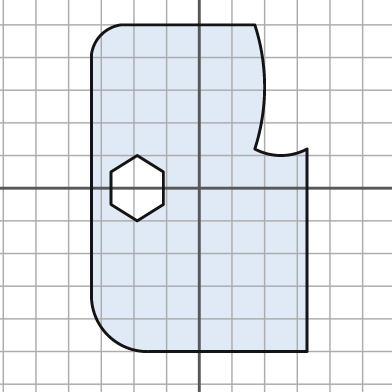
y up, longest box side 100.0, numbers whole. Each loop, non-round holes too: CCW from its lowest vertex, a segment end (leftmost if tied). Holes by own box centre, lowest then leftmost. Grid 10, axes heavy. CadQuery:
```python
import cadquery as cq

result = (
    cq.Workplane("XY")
    .moveTo(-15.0, -50.0)
    .lineTo(33.0, -50.0)
    .lineTo(33.0, 12.0)
    .threePointArc((25.0, 10.0), (17.0, 12.0))
    .threePointArc((20.0, 31.0), (17.0, 50.0))
    .lineTo(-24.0, 50.0)
    .threePointArc((-30.0, 47.0), (-33.0, 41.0))
    .lineTo(-33.0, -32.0)
    .threePointArc((-28.0, -45.0), (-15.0, -50.0))
    .close()
    .moveTo(-19.0, -10.0)
    .lineTo(-11.0, -5.0)
    .lineTo(-11.0, 5.0)
    .lineTo(-19.0, 10.0)
    .lineTo(-27.0, 5.0)
    .lineTo(-27.0, -5.0)
    .close()
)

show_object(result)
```